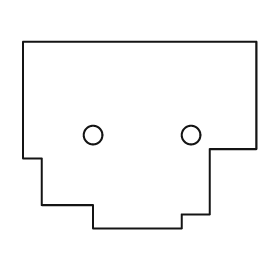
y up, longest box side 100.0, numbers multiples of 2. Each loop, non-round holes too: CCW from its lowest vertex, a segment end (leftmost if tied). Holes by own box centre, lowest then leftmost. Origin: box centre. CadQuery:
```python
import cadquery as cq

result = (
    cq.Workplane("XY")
    .moveTo(-20.0, -40.0)
    .lineTo(18.0, -40.0)
    .lineTo(18.0, -34.0)
    .lineTo(30.0, -34.0)
    .lineTo(30.0, -6.0)
    .lineTo(50.0, -6.0)
    .lineTo(50.0, 40.0)
    .lineTo(-50.0, 40.0)
    .lineTo(-50.0, -10.0)
    .lineTo(-42.0, -10.0)
    .lineTo(-42.0, -30.0)
    .lineTo(-20.0, -30.0)
    .close()
    .moveTo(-20.0, 0.0)
    .circle(4.0)
    .moveTo(22.0, 0.0)
    .circle(4.0)
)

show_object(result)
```